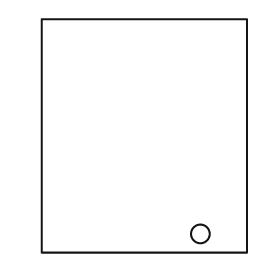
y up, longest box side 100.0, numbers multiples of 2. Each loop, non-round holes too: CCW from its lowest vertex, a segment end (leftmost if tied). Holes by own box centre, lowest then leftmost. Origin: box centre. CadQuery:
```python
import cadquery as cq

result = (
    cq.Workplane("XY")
    .moveTo(-44.0, -50.0)
    .lineTo(44.0, -50.0)
    .lineTo(44.0, 50.0)
    .lineTo(-44.0, 50.0)
    .close()
    .moveTo(24.0, -42.0)
    .circle(4.0)
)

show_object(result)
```